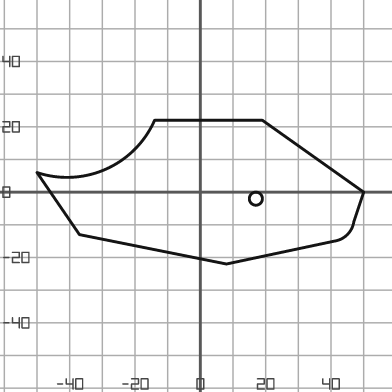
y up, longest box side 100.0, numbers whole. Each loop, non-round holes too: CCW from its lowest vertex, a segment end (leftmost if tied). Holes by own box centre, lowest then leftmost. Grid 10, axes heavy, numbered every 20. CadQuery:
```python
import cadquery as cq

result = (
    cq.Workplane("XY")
    .moveTo(8.0, -22.0)
    .lineTo(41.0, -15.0)
    .threePointArc((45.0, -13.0), (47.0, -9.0))
    .lineTo(50.0, 0.0)
    .lineTo(19.0, 22.0)
    .lineTo(-14.0, 22.0)
    .threePointArc((-29.0, 7.0), (-50.0, 6.0))
    .lineTo(-37.0, -13.0)
    .close()
    .moveTo(17.0, -2.0)
    .circle(2.0)
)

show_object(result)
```